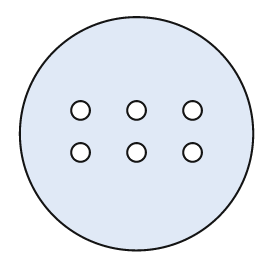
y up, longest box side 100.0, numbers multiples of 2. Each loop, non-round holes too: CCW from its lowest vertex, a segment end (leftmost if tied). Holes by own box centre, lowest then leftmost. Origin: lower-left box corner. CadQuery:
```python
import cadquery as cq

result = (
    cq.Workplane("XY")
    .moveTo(50.0, 50.0)
    .circle(50.0)
    .moveTo(26.0, 42.0)
    .circle(4.0)
    .moveTo(50.0, 42.0)
    .circle(4.0)
    .moveTo(74.0, 42.0)
    .circle(4.0)
    .moveTo(26.0, 60.0)
    .circle(4.0)
    .moveTo(50.0, 60.0)
    .circle(4.0)
    .moveTo(74.0, 60.0)
    .circle(4.0)
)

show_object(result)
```